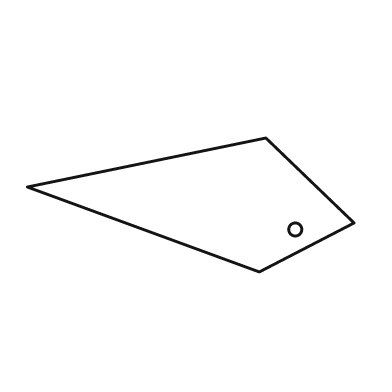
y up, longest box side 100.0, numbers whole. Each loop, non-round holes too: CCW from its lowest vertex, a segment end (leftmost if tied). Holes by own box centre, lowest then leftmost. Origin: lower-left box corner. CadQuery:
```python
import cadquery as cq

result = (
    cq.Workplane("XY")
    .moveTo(71.0, 0.0)
    .lineTo(100.0, 15.0)
    .lineTo(73.0, 41.0)
    .lineTo(0.0, 26.0)
    .close()
    .moveTo(82.0, 13.0)
    .circle(2.0)
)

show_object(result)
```